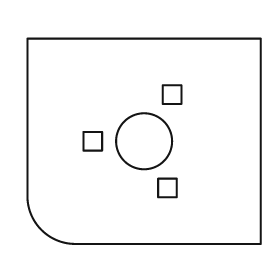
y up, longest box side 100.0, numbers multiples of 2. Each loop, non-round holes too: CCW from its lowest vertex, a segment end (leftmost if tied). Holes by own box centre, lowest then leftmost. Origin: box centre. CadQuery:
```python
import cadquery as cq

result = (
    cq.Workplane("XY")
    .moveTo(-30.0, -44.0)
    .lineTo(50.0, -44.0)
    .lineTo(50.0, 44.0)
    .lineTo(-50.0, 44.0)
    .lineTo(-50.0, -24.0)
    .threePointArc((-44.0, -38.0), (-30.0, -44.0))
    .close()
    .moveTo(6.0, -24.0)
    .lineTo(14.0, -24.0)
    .lineTo(14.0, -16.0)
    .lineTo(6.0, -16.0)
    .close()
    .moveTo(-26.0, -4.0)
    .lineTo(-18.0, -4.0)
    .lineTo(-18.0, 4.0)
    .lineTo(-26.0, 4.0)
    .close()
    .moveTo(0.0, 0.0)
    .circle(12.0)
    .moveTo(8.0, 16.0)
    .lineTo(16.0, 16.0)
    .lineTo(16.0, 24.0)
    .lineTo(8.0, 24.0)
    .close()
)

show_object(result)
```